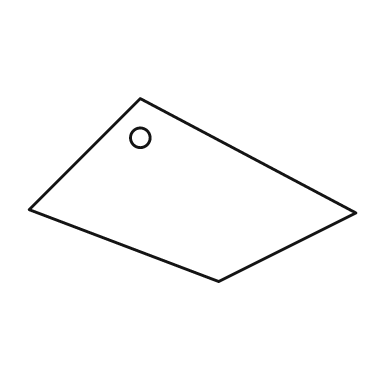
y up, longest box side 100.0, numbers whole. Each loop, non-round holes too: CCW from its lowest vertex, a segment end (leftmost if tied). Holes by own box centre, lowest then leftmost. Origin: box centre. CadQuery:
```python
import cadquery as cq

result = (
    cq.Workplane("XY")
    .moveTo(8.0, -28.0)
    .lineTo(50.0, -7.0)
    .lineTo(-16.0, 28.0)
    .lineTo(-50.0, -6.0)
    .close()
    .moveTo(-16.0, 16.0)
    .circle(3.0)
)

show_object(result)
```